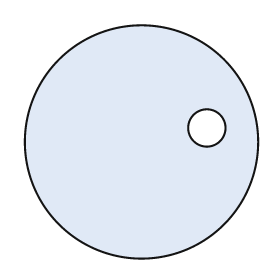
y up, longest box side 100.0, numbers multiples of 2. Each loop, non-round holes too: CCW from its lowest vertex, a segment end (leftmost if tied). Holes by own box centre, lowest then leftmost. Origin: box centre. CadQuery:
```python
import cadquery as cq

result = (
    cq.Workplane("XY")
    .moveTo(0.0, 0.0)
    .circle(50.0)
    .moveTo(28.0, 6.0)
    .circle(8.0)
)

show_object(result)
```